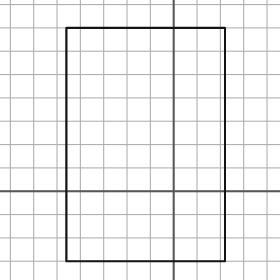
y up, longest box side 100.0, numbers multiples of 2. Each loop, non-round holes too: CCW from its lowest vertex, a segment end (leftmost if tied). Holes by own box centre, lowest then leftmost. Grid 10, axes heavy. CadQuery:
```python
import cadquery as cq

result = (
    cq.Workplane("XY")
    .moveTo(-46.0, -30.0)
    .lineTo(22.0, -30.0)
    .lineTo(22.0, 70.0)
    .lineTo(-46.0, 70.0)
    .close()
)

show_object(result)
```